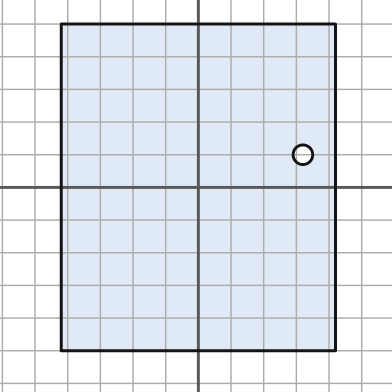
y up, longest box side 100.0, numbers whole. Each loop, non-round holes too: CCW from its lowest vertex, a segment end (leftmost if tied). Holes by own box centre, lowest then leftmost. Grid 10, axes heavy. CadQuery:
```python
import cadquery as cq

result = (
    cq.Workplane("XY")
    .moveTo(-42.0, -50.0)
    .lineTo(42.0, -50.0)
    .lineTo(42.0, 50.0)
    .lineTo(-42.0, 50.0)
    .close()
    .moveTo(32.0, 10.0)
    .circle(3.0)
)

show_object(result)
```